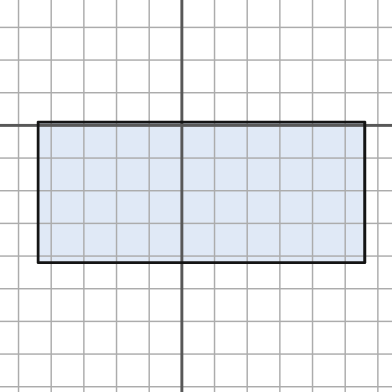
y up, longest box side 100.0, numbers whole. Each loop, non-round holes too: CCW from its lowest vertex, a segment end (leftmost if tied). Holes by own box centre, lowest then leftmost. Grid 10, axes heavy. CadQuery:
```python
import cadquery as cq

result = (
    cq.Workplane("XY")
    .moveTo(-44.0, -42.0)
    .lineTo(56.0, -42.0)
    .lineTo(56.0, 1.0)
    .lineTo(-44.0, 1.0)
    .close()
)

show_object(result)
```